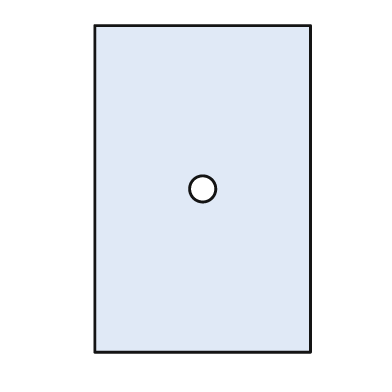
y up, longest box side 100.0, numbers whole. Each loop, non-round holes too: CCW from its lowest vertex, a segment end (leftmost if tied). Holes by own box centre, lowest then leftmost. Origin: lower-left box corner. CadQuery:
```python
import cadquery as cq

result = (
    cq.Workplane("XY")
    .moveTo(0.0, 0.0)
    .lineTo(66.0, 0.0)
    .lineTo(66.0, 100.0)
    .lineTo(0.0, 100.0)
    .close()
    .moveTo(33.0, 50.0)
    .circle(4.0)
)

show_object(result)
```